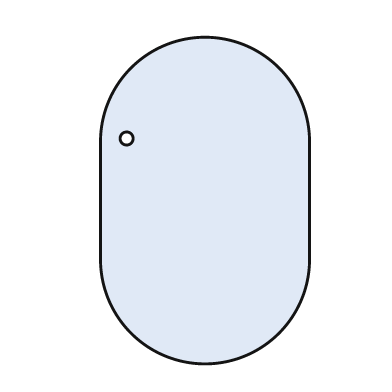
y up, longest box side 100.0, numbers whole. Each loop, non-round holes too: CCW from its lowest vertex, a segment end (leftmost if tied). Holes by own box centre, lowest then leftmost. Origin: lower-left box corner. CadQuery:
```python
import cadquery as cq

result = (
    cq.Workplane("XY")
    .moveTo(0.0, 32.0)
    .threePointArc((32.0, 0.0), (64.0, 32.0))
    .lineTo(64.0, 68.0)
    .threePointArc((32.0, 100.0), (0.0, 68.0))
    .close()
    .moveTo(8.0, 69.0)
    .circle(2.0)
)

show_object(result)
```